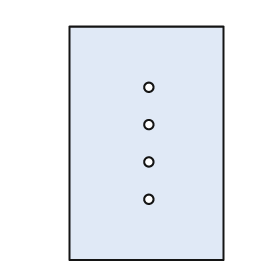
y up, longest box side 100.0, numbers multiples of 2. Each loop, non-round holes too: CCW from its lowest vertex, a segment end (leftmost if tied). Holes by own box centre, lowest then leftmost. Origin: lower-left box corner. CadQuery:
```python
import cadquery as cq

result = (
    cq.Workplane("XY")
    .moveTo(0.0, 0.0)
    .lineTo(66.0, 0.0)
    .lineTo(66.0, 100.0)
    .lineTo(0.0, 100.0)
    .close()
    .moveTo(34.0, 26.0)
    .circle(2.0)
    .moveTo(34.0, 42.0)
    .circle(2.0)
    .moveTo(34.0, 58.0)
    .circle(2.0)
    .moveTo(34.0, 74.0)
    .circle(2.0)
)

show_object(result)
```